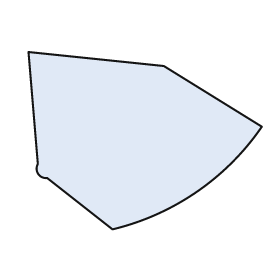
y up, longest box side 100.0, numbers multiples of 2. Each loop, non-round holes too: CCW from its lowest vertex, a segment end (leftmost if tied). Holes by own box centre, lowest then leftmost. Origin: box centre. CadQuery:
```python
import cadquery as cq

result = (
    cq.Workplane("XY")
    .moveTo(-14.0, -38.0)
    .threePointArc((22.0, -22.0), (50.0, 6.0))
    .lineTo(8.0, 32.0)
    .lineTo(-50.0, 38.0)
    .lineTo(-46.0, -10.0)
    .threePointArc((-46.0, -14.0), (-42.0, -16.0))
    .close()
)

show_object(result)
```